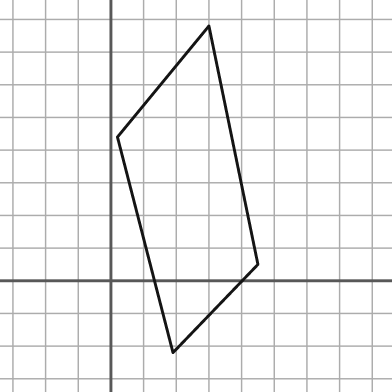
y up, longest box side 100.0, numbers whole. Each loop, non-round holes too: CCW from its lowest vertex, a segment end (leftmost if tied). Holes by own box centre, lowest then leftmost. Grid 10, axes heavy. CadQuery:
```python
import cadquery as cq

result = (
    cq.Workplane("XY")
    .moveTo(19.0, -22.0)
    .lineTo(45.0, 5.0)
    .lineTo(30.0, 78.0)
    .lineTo(2.0, 44.0)
    .close()
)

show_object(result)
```